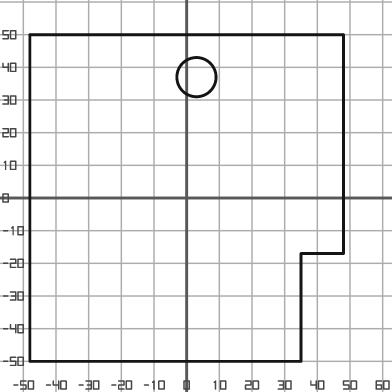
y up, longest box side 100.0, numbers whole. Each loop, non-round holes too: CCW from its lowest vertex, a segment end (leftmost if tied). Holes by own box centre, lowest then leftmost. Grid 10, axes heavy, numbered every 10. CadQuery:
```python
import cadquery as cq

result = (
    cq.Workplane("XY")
    .moveTo(-48.0, -50.0)
    .lineTo(35.0, -50.0)
    .lineTo(35.0, -17.0)
    .lineTo(48.0, -17.0)
    .lineTo(48.0, 50.0)
    .lineTo(-48.0, 50.0)
    .close()
    .moveTo(3.0, 37.0)
    .circle(6.0)
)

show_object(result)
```